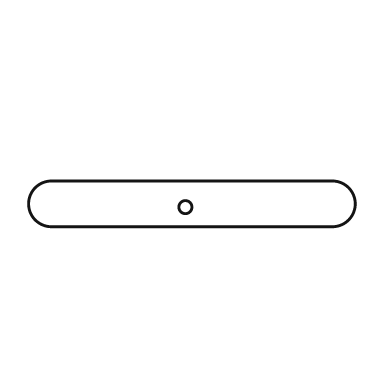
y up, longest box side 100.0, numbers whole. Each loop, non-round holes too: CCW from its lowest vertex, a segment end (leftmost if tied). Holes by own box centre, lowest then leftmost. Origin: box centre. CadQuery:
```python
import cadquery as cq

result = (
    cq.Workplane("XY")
    .moveTo(-43.0, -7.0)
    .lineTo(43.0, -7.0)
    .threePointArc((50.0, 0.0), (43.0, 7.0))
    .lineTo(-43.0, 7.0)
    .threePointArc((-50.0, 0.0), (-43.0, -7.0))
    .close()
    .moveTo(-2.0, -1.0)
    .circle(2.0)
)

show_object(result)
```